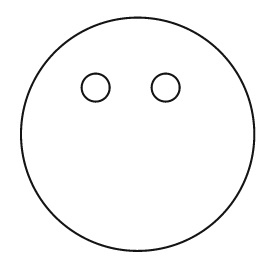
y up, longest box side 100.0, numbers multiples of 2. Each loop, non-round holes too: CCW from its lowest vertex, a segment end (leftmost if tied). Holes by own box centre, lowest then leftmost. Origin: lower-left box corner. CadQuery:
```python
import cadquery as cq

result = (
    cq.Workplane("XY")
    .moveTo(50.0, 50.0)
    .circle(50.0)
    .moveTo(32.0, 70.0)
    .circle(6.0)
    .moveTo(62.0, 70.0)
    .circle(6.0)
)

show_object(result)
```